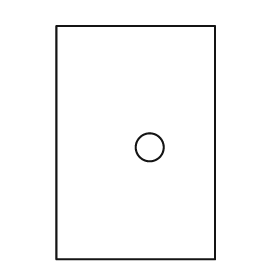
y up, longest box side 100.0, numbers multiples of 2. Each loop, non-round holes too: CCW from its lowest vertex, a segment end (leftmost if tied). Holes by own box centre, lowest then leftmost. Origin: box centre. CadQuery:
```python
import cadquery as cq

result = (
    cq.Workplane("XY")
    .moveTo(-34.0, -50.0)
    .lineTo(34.0, -50.0)
    .lineTo(34.0, 50.0)
    .lineTo(-34.0, 50.0)
    .close()
    .moveTo(6.0, -2.0)
    .circle(6.0)
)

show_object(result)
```